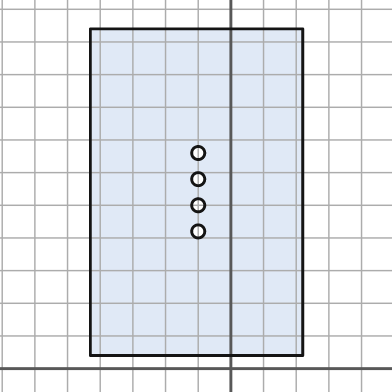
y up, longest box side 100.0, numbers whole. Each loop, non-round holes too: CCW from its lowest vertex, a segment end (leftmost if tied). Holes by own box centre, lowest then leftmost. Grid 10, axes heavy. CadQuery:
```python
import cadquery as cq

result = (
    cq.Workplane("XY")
    .moveTo(-43.0, 4.0)
    .lineTo(22.0, 4.0)
    .lineTo(22.0, 104.0)
    .lineTo(-43.0, 104.0)
    .close()
    .moveTo(-10.0, 42.0)
    .circle(2.0)
    .moveTo(-10.0, 50.0)
    .circle(2.0)
    .moveTo(-10.0, 58.0)
    .circle(2.0)
    .moveTo(-10.0, 66.0)
    .circle(2.0)
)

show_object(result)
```